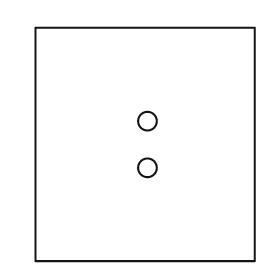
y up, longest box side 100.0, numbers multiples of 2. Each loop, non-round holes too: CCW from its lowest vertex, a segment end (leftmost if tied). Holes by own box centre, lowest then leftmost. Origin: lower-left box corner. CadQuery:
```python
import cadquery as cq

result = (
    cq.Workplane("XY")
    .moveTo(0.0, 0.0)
    .lineTo(94.0, 0.0)
    .lineTo(94.0, 100.0)
    .lineTo(0.0, 100.0)
    .close()
    .moveTo(48.0, 40.0)
    .circle(4.0)
    .moveTo(48.0, 60.0)
    .circle(4.0)
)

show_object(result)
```